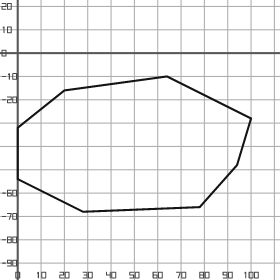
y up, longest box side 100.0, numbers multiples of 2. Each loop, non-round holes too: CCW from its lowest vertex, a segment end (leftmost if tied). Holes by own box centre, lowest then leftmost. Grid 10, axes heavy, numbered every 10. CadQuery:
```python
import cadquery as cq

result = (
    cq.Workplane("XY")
    .moveTo(28.0, -68.0)
    .lineTo(78.0, -66.0)
    .lineTo(94.0, -48.0)
    .lineTo(100.0, -28.0)
    .lineTo(64.0, -10.0)
    .lineTo(20.0, -16.0)
    .lineTo(0.0, -32.0)
    .lineTo(0.0, -54.0)
    .close()
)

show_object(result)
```